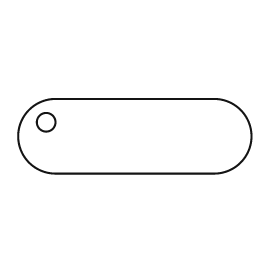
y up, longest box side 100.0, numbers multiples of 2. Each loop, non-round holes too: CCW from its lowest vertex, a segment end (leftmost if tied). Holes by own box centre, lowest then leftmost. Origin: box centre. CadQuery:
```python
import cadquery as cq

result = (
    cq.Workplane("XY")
    .moveTo(-34.0, -16.0)
    .lineTo(34.0, -16.0)
    .threePointArc((50.0, 0.0), (34.0, 16.0))
    .lineTo(-34.0, 16.0)
    .threePointArc((-50.0, 0.0), (-34.0, -16.0))
    .close()
    .moveTo(-38.0, 6.0)
    .circle(4.0)
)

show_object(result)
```